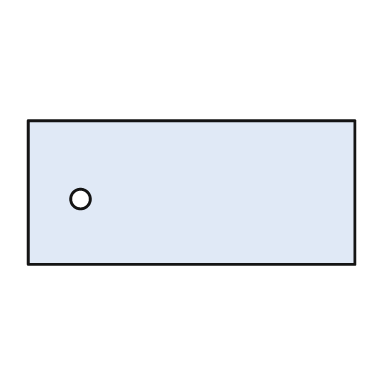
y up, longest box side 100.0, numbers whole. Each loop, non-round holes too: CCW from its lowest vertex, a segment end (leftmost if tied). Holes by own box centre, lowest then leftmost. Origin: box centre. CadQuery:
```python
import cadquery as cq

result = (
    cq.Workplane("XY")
    .moveTo(-50.0, -22.0)
    .lineTo(50.0, -22.0)
    .lineTo(50.0, 22.0)
    .lineTo(-50.0, 22.0)
    .close()
    .moveTo(-34.0, -2.0)
    .circle(3.0)
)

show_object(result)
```